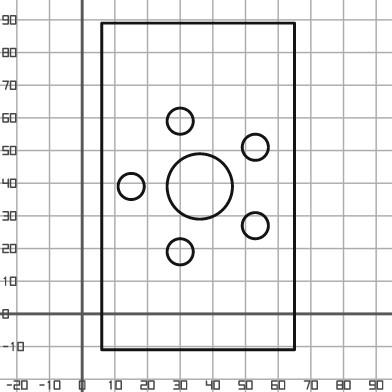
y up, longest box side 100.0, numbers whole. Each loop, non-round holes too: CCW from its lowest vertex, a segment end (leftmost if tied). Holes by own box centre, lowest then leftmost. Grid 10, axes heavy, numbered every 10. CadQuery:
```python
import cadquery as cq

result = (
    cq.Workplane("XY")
    .moveTo(6.0, -11.0)
    .lineTo(65.0, -11.0)
    .lineTo(65.0, 89.0)
    .lineTo(6.0, 89.0)
    .close()
    .moveTo(30.0, 19.0)
    .circle(4.0)
    .moveTo(53.0, 27.0)
    .circle(4.0)
    .moveTo(15.0, 39.0)
    .circle(4.0)
    .moveTo(36.0, 39.0)
    .circle(10.0)
    .moveTo(53.0, 51.0)
    .circle(4.0)
    .moveTo(30.0, 59.0)
    .circle(4.0)
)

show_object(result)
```